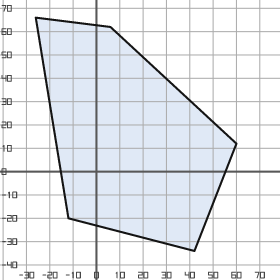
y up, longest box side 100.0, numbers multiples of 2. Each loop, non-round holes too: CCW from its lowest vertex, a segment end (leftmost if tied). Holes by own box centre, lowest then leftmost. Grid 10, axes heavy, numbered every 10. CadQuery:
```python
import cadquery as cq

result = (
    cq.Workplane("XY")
    .moveTo(42.0, -34.0)
    .lineTo(60.0, 12.0)
    .lineTo(6.0, 62.0)
    .lineTo(-26.0, 66.0)
    .lineTo(-12.0, -20.0)
    .close()
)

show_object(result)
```